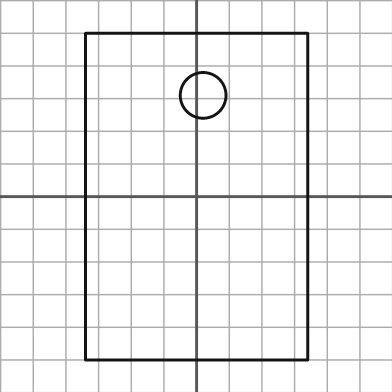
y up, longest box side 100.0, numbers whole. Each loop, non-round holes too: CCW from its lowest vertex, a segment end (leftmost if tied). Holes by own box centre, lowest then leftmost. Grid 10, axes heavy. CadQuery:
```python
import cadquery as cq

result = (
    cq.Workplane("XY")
    .moveTo(-34.0, -50.0)
    .lineTo(34.0, -50.0)
    .lineTo(34.0, 50.0)
    .lineTo(-34.0, 50.0)
    .close()
    .moveTo(2.0, 31.0)
    .circle(7.0)
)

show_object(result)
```